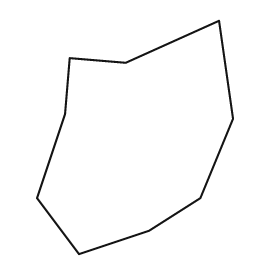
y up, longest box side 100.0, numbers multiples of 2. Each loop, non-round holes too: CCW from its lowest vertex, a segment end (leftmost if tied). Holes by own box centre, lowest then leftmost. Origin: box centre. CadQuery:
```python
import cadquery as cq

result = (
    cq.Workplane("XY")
    .moveTo(-24.0, -50.0)
    .lineTo(6.0, -40.0)
    .lineTo(28.0, -26.0)
    .lineTo(42.0, 8.0)
    .lineTo(36.0, 50.0)
    .lineTo(-4.0, 32.0)
    .lineTo(-28.0, 34.0)
    .lineTo(-30.0, 10.0)
    .lineTo(-42.0, -26.0)
    .close()
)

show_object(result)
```